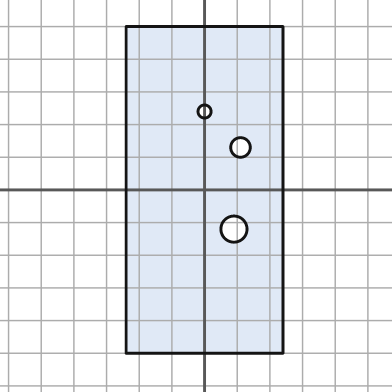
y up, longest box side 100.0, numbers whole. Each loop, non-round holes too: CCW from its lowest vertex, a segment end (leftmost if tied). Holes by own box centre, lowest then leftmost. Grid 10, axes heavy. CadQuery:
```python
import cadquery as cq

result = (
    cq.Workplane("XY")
    .moveTo(-24.0, -50.0)
    .lineTo(24.0, -50.0)
    .lineTo(24.0, 50.0)
    .lineTo(-24.0, 50.0)
    .close()
    .moveTo(9.0, -12.0)
    .circle(4.0)
    .moveTo(11.0, 13.0)
    .circle(3.0)
    .moveTo(0.0, 24.0)
    .circle(2.0)
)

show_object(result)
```